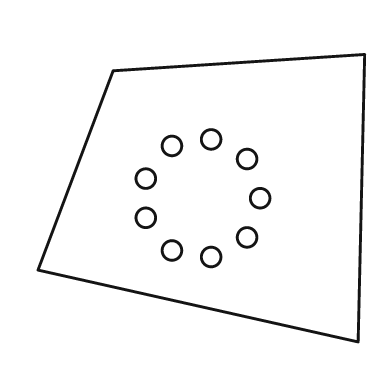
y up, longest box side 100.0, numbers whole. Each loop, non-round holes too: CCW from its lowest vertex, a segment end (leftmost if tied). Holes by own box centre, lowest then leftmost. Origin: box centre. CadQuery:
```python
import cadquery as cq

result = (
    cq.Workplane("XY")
    .moveTo(48.0, -44.0)
    .lineTo(50.0, 44.0)
    .lineTo(-27.0, 39.0)
    .lineTo(-50.0, -22.0)
    .close()
    .moveTo(3.0, -18.0)
    .circle(3.0)
    .moveTo(-9.0, -16.0)
    .circle(3.0)
    .moveTo(14.0, -12.0)
    .circle(3.0)
    .moveTo(-17.0, -6.0)
    .circle(3.0)
    .moveTo(18.0, 0.0)
    .circle(3.0)
    .moveTo(-17.0, 6.0)
    .circle(3.0)
    .moveTo(14.0, 12.0)
    .circle(3.0)
    .moveTo(-9.0, 16.0)
    .circle(3.0)
    .moveTo(3.0, 18.0)
    .circle(3.0)
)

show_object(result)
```